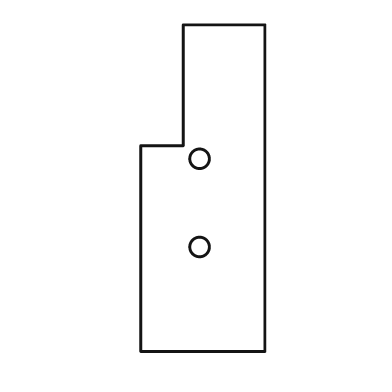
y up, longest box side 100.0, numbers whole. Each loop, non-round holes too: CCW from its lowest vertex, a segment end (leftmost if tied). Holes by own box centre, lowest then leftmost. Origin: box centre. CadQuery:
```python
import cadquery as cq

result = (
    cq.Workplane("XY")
    .moveTo(-19.0, -50.0)
    .lineTo(19.0, -50.0)
    .lineTo(19.0, 50.0)
    .lineTo(-6.0, 50.0)
    .lineTo(-6.0, 13.0)
    .lineTo(-19.0, 13.0)
    .close()
    .moveTo(-1.0, -18.0)
    .circle(3.0)
    .moveTo(-1.0, 9.0)
    .circle(3.0)
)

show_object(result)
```